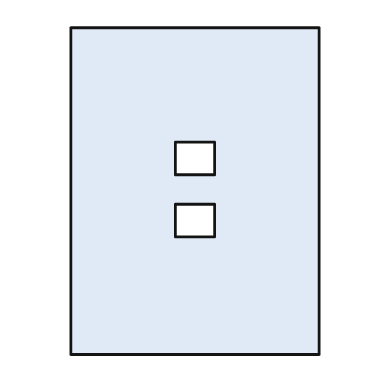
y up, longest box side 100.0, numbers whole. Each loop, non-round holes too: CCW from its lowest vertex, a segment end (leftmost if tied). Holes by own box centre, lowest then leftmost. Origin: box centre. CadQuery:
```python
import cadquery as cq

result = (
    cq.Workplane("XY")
    .moveTo(-38.0, -50.0)
    .lineTo(38.0, -50.0)
    .lineTo(38.0, 50.0)
    .lineTo(-38.0, 50.0)
    .close()
    .moveTo(-6.0, -14.0)
    .lineTo(6.0, -14.0)
    .lineTo(6.0, -4.0)
    .lineTo(-6.0, -4.0)
    .close()
    .moveTo(-6.0, 5.0)
    .lineTo(6.0, 5.0)
    .lineTo(6.0, 15.0)
    .lineTo(-6.0, 15.0)
    .close()
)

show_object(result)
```